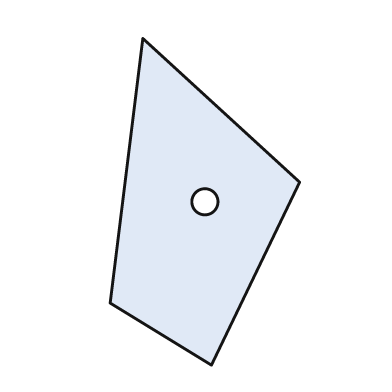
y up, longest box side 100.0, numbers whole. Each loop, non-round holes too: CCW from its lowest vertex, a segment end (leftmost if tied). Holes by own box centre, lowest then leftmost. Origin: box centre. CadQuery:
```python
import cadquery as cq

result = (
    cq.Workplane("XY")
    .moveTo(2.0, -50.0)
    .lineTo(29.0, 6.0)
    .lineTo(-19.0, 50.0)
    .lineTo(-29.0, -31.0)
    .close()
    .moveTo(0.0, 0.0)
    .circle(4.0)
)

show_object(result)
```